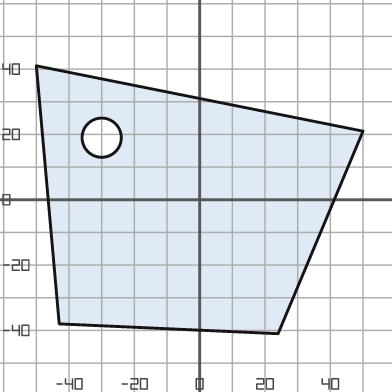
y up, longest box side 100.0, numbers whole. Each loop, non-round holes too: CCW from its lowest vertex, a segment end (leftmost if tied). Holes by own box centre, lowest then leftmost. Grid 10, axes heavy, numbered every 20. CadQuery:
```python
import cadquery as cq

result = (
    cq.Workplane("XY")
    .moveTo(24.0, -41.0)
    .lineTo(50.0, 21.0)
    .lineTo(-50.0, 41.0)
    .lineTo(-43.0, -38.0)
    .close()
    .moveTo(-30.0, 19.0)
    .circle(6.0)
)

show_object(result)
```